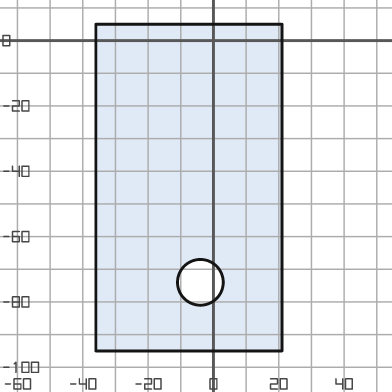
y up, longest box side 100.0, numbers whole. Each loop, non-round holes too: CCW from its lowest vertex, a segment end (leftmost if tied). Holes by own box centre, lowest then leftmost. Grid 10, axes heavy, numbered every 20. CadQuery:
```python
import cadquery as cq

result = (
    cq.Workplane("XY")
    .moveTo(-36.0, -95.0)
    .lineTo(21.0, -95.0)
    .lineTo(21.0, 5.0)
    .lineTo(-36.0, 5.0)
    .close()
    .moveTo(-4.0, -74.0)
    .circle(7.0)
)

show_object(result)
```